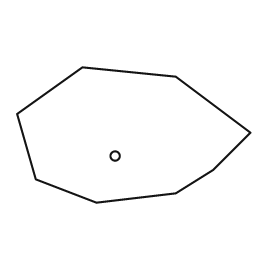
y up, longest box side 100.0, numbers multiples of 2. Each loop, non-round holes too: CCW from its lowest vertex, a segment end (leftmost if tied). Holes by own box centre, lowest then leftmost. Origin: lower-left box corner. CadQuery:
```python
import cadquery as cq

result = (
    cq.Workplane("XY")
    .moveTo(34.0, 0.0)
    .lineTo(68.0, 4.0)
    .lineTo(84.0, 14.0)
    .lineTo(100.0, 30.0)
    .lineTo(68.0, 54.0)
    .lineTo(28.0, 58.0)
    .lineTo(0.0, 38.0)
    .lineTo(8.0, 10.0)
    .close()
    .moveTo(42.0, 20.0)
    .circle(2.0)
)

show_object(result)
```